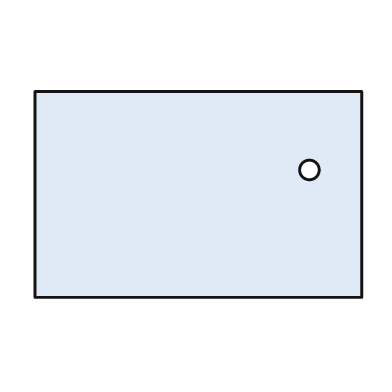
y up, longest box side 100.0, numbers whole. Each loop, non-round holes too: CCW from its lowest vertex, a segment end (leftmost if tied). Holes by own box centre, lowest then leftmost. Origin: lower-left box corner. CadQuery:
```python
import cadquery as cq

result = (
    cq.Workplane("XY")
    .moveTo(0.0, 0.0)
    .lineTo(100.0, 0.0)
    .lineTo(100.0, 63.0)
    .lineTo(0.0, 63.0)
    .close()
    .moveTo(84.0, 39.0)
    .circle(3.0)
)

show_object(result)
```